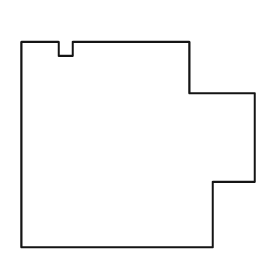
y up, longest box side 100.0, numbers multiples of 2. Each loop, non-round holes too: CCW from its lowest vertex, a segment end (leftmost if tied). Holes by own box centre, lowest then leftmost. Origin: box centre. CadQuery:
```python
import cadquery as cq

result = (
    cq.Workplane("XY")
    .moveTo(-50.0, -44.0)
    .lineTo(32.0, -44.0)
    .lineTo(32.0, -16.0)
    .lineTo(50.0, -16.0)
    .lineTo(50.0, 22.0)
    .lineTo(22.0, 22.0)
    .lineTo(22.0, 44.0)
    .lineTo(-28.0, 44.0)
    .lineTo(-28.0, 38.0)
    .lineTo(-34.0, 38.0)
    .lineTo(-34.0, 44.0)
    .lineTo(-50.0, 44.0)
    .close()
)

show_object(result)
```